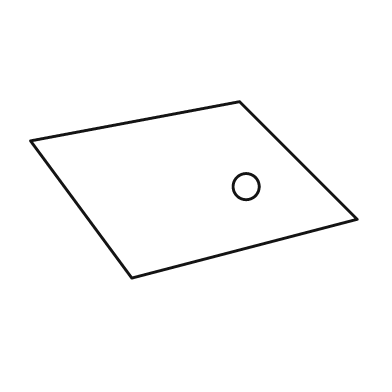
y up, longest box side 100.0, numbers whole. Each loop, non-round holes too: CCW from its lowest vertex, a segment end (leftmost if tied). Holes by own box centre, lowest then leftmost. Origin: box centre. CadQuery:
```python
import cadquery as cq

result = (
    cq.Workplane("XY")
    .moveTo(-19.0, -27.0)
    .lineTo(50.0, -9.0)
    .lineTo(14.0, 27.0)
    .lineTo(-50.0, 15.0)
    .close()
    .moveTo(16.0, 1.0)
    .circle(4.0)
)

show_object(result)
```